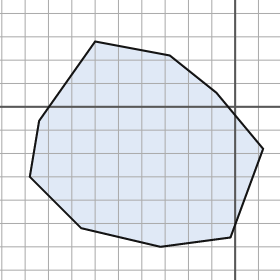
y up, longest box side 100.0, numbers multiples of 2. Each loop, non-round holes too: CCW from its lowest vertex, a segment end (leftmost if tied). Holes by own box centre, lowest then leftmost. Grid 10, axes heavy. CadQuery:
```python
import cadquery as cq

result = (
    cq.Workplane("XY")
    .moveTo(-32.0, -60.0)
    .lineTo(-2.0, -56.0)
    .lineTo(12.0, -18.0)
    .lineTo(-8.0, 6.0)
    .lineTo(-28.0, 22.0)
    .lineTo(-60.0, 28.0)
    .lineTo(-84.0, -6.0)
    .lineTo(-88.0, -30.0)
    .lineTo(-66.0, -52.0)
    .close()
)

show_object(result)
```